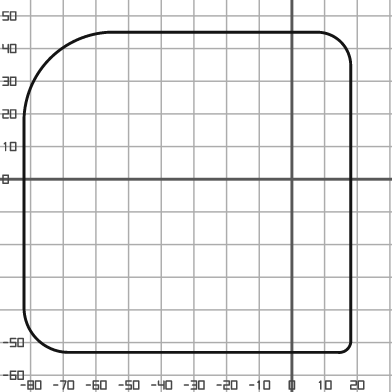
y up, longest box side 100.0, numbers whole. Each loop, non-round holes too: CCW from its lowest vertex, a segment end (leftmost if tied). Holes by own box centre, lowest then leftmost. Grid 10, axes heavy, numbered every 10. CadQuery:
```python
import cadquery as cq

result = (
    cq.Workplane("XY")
    .moveTo(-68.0, -53.0)
    .lineTo(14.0, -53.0)
    .threePointArc((17.0, -52.0), (18.0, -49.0))
    .lineTo(18.0, 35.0)
    .threePointArc((15.0, 42.0), (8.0, 45.0))
    .lineTo(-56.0, 45.0)
    .threePointArc((-74.0, 37.0), (-82.0, 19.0))
    .lineTo(-82.0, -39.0)
    .threePointArc((-78.0, -49.0), (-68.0, -53.0))
    .close()
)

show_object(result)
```